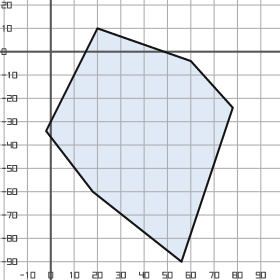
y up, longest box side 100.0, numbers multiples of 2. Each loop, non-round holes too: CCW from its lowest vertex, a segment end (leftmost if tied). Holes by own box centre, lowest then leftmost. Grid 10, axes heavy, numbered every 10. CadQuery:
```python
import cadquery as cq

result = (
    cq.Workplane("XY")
    .moveTo(56.0, -90.0)
    .lineTo(78.0, -24.0)
    .lineTo(60.0, -4.0)
    .lineTo(20.0, 10.0)
    .lineTo(-2.0, -34.0)
    .lineTo(18.0, -60.0)
    .close()
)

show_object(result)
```